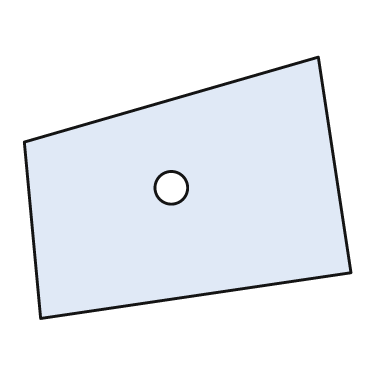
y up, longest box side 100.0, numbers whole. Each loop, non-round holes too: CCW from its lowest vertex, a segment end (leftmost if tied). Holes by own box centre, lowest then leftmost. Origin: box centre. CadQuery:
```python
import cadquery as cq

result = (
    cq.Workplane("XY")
    .moveTo(-45.0, -40.0)
    .lineTo(50.0, -26.0)
    .lineTo(40.0, 40.0)
    .lineTo(-50.0, 14.0)
    .close()
    .moveTo(-5.0, 0.0)
    .circle(5.0)
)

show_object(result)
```